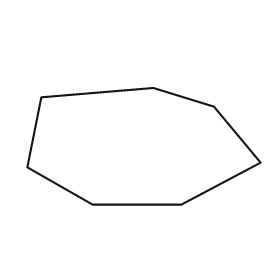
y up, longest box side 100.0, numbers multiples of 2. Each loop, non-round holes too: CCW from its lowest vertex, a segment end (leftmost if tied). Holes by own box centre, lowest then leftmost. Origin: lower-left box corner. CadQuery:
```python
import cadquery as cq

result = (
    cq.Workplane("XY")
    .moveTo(28.0, 0.0)
    .lineTo(66.0, 0.0)
    .lineTo(100.0, 18.0)
    .lineTo(80.0, 42.0)
    .lineTo(54.0, 50.0)
    .lineTo(6.0, 46.0)
    .lineTo(0.0, 16.0)
    .close()
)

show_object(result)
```